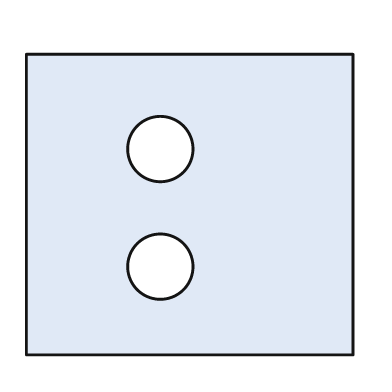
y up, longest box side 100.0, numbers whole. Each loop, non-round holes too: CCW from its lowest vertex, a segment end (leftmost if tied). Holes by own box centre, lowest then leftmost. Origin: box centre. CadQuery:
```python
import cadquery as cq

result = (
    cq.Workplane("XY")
    .moveTo(-50.0, -46.0)
    .lineTo(50.0, -46.0)
    .lineTo(50.0, 46.0)
    .lineTo(-50.0, 46.0)
    .close()
    .moveTo(-9.0, -19.0)
    .circle(10.0)
    .moveTo(-9.0, 17.0)
    .circle(10.0)
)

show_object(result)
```